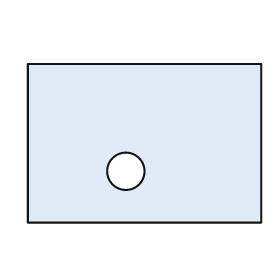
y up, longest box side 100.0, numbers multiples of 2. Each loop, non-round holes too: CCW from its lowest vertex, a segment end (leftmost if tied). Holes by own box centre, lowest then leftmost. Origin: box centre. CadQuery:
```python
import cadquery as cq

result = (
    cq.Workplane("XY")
    .moveTo(-50.0, -34.0)
    .lineTo(50.0, -34.0)
    .lineTo(50.0, 34.0)
    .lineTo(-50.0, 34.0)
    .close()
    .moveTo(-8.0, -12.0)
    .circle(8.0)
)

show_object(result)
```